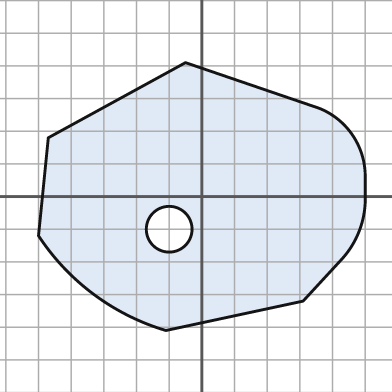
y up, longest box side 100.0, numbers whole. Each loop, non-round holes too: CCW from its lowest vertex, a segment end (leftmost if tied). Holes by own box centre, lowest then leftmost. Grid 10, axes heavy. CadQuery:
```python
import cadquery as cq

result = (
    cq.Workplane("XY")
    .moveTo(-11.0, -41.0)
    .lineTo(31.0, -32.0)
    .lineTo(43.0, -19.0)
    .threePointArc((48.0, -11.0), (50.0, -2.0))
    .lineTo(50.0, 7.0)
    .threePointArc((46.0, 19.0), (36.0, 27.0))
    .lineTo(-5.0, 41.0)
    .lineTo(-47.0, 18.0)
    .lineTo(-50.0, -12.0)
    .threePointArc((-33.0, -30.0), (-11.0, -41.0))
    .close()
    .moveTo(-10.0, -10.0)
    .circle(7.0)
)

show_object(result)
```